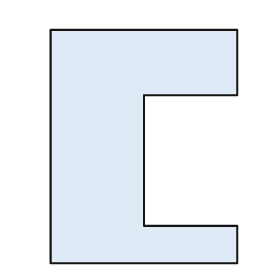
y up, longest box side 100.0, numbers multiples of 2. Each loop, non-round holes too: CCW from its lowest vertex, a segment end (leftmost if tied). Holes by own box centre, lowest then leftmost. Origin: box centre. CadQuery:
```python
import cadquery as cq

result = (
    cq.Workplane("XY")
    .moveTo(-40.0, -50.0)
    .lineTo(40.0, -50.0)
    .lineTo(40.0, -34.0)
    .lineTo(0.0, -34.0)
    .lineTo(0.0, 22.0)
    .lineTo(40.0, 22.0)
    .lineTo(40.0, 50.0)
    .lineTo(-40.0, 50.0)
    .close()
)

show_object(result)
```